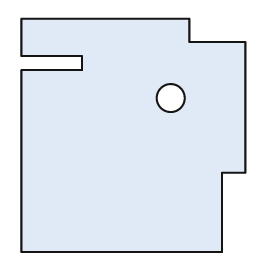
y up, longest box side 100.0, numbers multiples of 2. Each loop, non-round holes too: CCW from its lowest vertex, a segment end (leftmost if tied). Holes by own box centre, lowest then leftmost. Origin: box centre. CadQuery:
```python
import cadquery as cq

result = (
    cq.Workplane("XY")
    .moveTo(-48.0, -50.0)
    .lineTo(38.0, -50.0)
    .lineTo(38.0, -16.0)
    .lineTo(48.0, -16.0)
    .lineTo(48.0, 40.0)
    .lineTo(24.0, 40.0)
    .lineTo(24.0, 50.0)
    .lineTo(-48.0, 50.0)
    .lineTo(-48.0, 34.0)
    .lineTo(-22.0, 34.0)
    .lineTo(-22.0, 28.0)
    .lineTo(-48.0, 28.0)
    .close()
    .moveTo(16.0, 16.0)
    .circle(6.0)
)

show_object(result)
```